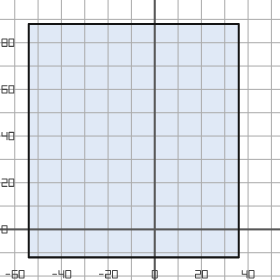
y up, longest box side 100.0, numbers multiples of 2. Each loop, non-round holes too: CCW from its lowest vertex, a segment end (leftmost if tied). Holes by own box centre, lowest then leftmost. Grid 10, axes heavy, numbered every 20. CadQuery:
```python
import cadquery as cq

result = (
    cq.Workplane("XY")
    .moveTo(-54.0, -12.0)
    .lineTo(36.0, -12.0)
    .lineTo(36.0, 88.0)
    .lineTo(-54.0, 88.0)
    .close()
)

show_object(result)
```